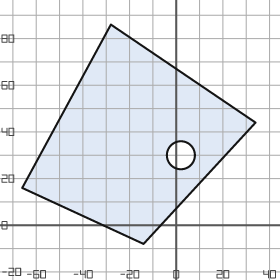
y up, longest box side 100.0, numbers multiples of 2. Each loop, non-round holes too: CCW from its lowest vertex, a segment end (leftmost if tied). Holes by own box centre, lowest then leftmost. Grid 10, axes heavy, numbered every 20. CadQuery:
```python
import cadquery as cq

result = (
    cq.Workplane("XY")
    .moveTo(-14.0, -8.0)
    .lineTo(34.0, 44.0)
    .lineTo(-28.0, 86.0)
    .lineTo(-66.0, 16.0)
    .close()
    .moveTo(2.0, 30.0)
    .circle(6.0)
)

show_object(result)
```